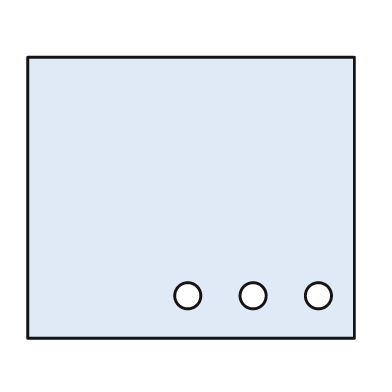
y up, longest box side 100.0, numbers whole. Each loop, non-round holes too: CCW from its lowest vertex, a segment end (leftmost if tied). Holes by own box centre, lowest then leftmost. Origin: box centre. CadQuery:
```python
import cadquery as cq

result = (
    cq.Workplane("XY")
    .moveTo(-50.0, -43.0)
    .lineTo(50.0, -43.0)
    .lineTo(50.0, 43.0)
    .lineTo(-50.0, 43.0)
    .close()
    .moveTo(-1.0, -30.0)
    .circle(4.0)
    .moveTo(19.0, -30.0)
    .circle(4.0)
    .moveTo(39.0, -30.0)
    .circle(4.0)
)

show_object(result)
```